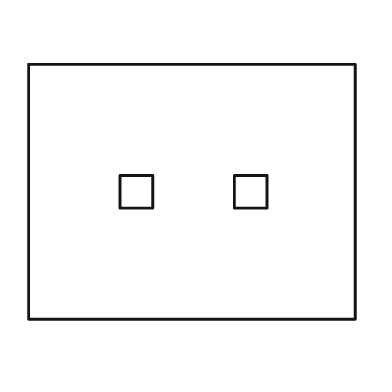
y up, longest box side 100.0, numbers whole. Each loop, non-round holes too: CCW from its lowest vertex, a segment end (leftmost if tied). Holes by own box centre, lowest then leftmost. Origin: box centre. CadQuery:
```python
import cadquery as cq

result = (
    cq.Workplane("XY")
    .moveTo(-50.0, -39.0)
    .lineTo(50.0, -39.0)
    .lineTo(50.0, 39.0)
    .lineTo(-50.0, 39.0)
    .close()
    .moveTo(-22.0, -5.0)
    .lineTo(-12.0, -5.0)
    .lineTo(-12.0, 5.0)
    .lineTo(-22.0, 5.0)
    .close()
    .moveTo(13.0, -5.0)
    .lineTo(23.0, -5.0)
    .lineTo(23.0, 5.0)
    .lineTo(13.0, 5.0)
    .close()
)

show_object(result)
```